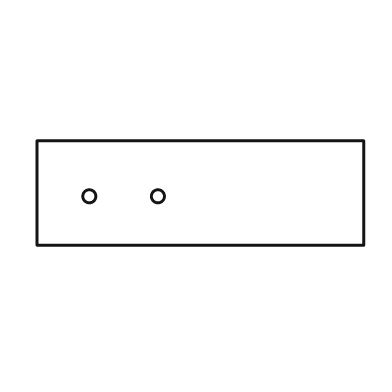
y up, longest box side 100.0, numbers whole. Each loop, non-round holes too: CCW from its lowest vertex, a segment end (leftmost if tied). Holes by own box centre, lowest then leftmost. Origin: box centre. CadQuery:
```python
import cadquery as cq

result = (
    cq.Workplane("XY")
    .moveTo(-50.0, -16.0)
    .lineTo(50.0, -16.0)
    .lineTo(50.0, 16.0)
    .lineTo(-50.0, 16.0)
    .close()
    .moveTo(-34.0, -1.0)
    .circle(2.0)
    .moveTo(-13.0, -1.0)
    .circle(2.0)
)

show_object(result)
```